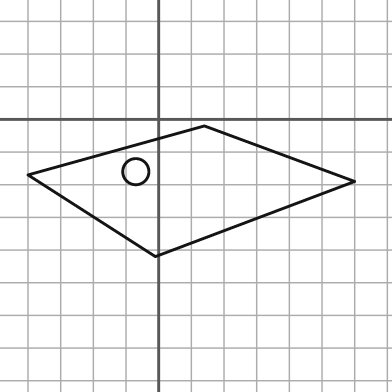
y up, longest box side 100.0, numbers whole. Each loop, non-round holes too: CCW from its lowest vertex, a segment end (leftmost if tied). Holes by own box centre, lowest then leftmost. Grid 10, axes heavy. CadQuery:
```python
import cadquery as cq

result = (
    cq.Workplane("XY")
    .moveTo(-1.0, -42.0)
    .lineTo(60.0, -19.0)
    .lineTo(14.0, -2.0)
    .lineTo(-40.0, -17.0)
    .close()
    .moveTo(-7.0, -16.0)
    .circle(4.0)
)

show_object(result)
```